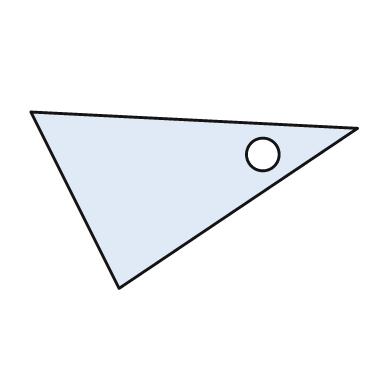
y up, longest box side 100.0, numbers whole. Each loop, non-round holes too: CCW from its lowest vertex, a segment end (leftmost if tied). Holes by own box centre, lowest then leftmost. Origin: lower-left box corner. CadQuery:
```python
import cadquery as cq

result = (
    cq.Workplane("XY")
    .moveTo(27.0, 0.0)
    .lineTo(100.0, 49.0)
    .lineTo(0.0, 54.0)
    .close()
    .moveTo(71.0, 41.0)
    .circle(5.0)
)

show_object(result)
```